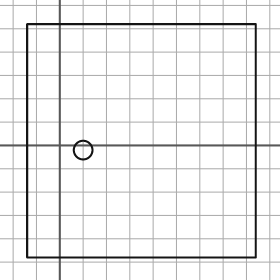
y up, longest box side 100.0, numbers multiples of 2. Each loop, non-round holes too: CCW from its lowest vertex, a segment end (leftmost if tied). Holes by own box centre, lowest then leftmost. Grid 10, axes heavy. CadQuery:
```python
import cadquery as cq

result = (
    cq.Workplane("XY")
    .moveTo(-14.0, -48.0)
    .lineTo(84.0, -48.0)
    .lineTo(84.0, 52.0)
    .lineTo(-14.0, 52.0)
    .close()
    .moveTo(10.0, -2.0)
    .circle(4.0)
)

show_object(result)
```